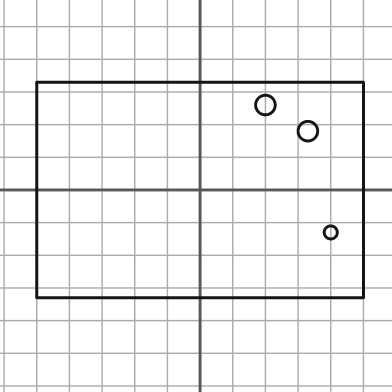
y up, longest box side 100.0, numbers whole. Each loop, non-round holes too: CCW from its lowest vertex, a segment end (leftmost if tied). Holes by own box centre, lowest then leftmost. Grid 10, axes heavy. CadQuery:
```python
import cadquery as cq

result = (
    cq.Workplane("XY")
    .moveTo(-50.0, -33.0)
    .lineTo(50.0, -33.0)
    .lineTo(50.0, 33.0)
    .lineTo(-50.0, 33.0)
    .close()
    .moveTo(40.0, -13.0)
    .circle(2.0)
    .moveTo(33.0, 18.0)
    .circle(3.0)
    .moveTo(20.0, 26.0)
    .circle(3.0)
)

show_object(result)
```